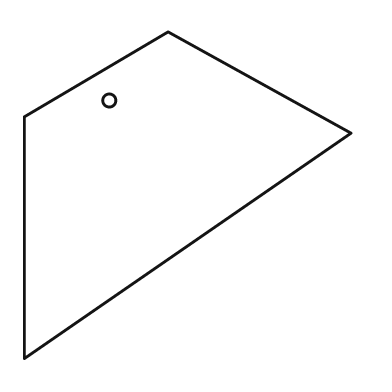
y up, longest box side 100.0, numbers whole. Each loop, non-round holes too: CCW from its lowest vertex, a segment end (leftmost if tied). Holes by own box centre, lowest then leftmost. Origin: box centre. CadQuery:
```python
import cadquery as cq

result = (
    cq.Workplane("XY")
    .moveTo(-50.0, -50.0)
    .lineTo(50.0, 19.0)
    .lineTo(-6.0, 50.0)
    .lineTo(-50.0, 24.0)
    .close()
    .moveTo(-24.0, 29.0)
    .circle(2.0)
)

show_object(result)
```